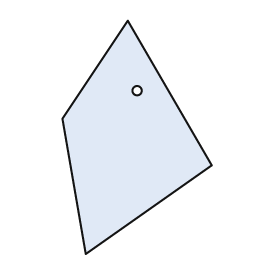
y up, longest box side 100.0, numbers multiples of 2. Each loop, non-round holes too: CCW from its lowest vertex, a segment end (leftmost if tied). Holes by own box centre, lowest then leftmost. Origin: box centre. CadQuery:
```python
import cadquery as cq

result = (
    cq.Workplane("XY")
    .moveTo(-22.0, -50.0)
    .lineTo(32.0, -12.0)
    .lineTo(-4.0, 50.0)
    .lineTo(-32.0, 8.0)
    .close()
    .moveTo(0.0, 20.0)
    .circle(2.0)
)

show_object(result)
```